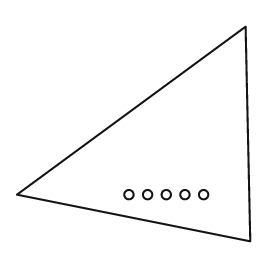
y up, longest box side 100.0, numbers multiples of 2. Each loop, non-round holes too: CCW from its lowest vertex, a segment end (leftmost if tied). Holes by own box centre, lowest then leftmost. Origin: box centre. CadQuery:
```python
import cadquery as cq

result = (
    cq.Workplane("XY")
    .moveTo(50.0, -46.0)
    .lineTo(48.0, 46.0)
    .lineTo(-50.0, -26.0)
    .close()
    .moveTo(-2.0, -26.0)
    .circle(2.0)
    .moveTo(6.0, -26.0)
    .circle(2.0)
    .moveTo(14.0, -26.0)
    .circle(2.0)
    .moveTo(22.0, -26.0)
    .circle(2.0)
    .moveTo(30.0, -26.0)
    .circle(2.0)
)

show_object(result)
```